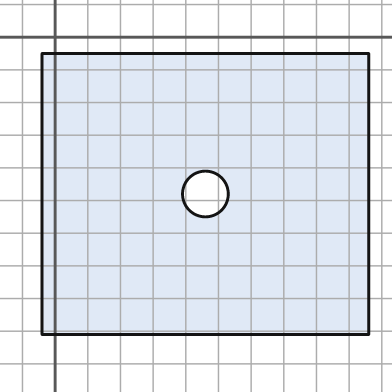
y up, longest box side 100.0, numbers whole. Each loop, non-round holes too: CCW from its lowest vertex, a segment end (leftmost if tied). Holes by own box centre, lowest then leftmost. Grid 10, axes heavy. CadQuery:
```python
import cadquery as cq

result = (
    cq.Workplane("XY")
    .moveTo(-4.0, -91.0)
    .lineTo(96.0, -91.0)
    .lineTo(96.0, -5.0)
    .lineTo(-4.0, -5.0)
    .close()
    .moveTo(46.0, -48.0)
    .circle(7.0)
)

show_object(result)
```